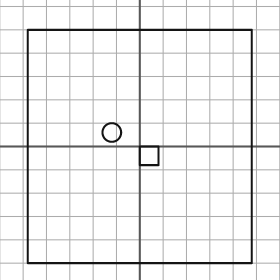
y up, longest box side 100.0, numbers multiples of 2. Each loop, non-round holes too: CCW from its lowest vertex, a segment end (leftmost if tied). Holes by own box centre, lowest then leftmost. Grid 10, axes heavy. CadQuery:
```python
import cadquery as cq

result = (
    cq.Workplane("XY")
    .moveTo(-48.0, -50.0)
    .lineTo(48.0, -50.0)
    .lineTo(48.0, 50.0)
    .lineTo(-48.0, 50.0)
    .close()
    .moveTo(0.0, -8.0)
    .lineTo(8.0, -8.0)
    .lineTo(8.0, 0.0)
    .lineTo(0.0, 0.0)
    .close()
    .moveTo(-12.0, 6.0)
    .circle(4.0)
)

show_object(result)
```